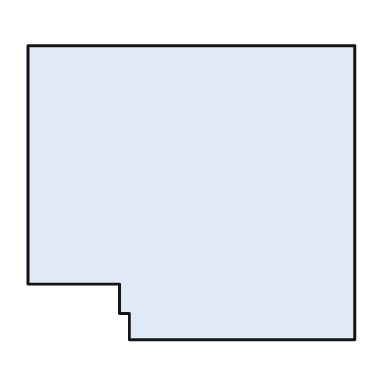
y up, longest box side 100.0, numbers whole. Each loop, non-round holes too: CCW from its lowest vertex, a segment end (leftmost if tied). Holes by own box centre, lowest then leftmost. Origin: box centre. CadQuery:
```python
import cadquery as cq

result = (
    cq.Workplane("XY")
    .moveTo(-19.0, -45.0)
    .lineTo(50.0, -45.0)
    .lineTo(50.0, 45.0)
    .lineTo(-50.0, 45.0)
    .lineTo(-50.0, -28.0)
    .lineTo(-22.0, -28.0)
    .lineTo(-22.0, -37.0)
    .lineTo(-19.0, -37.0)
    .close()
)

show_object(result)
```